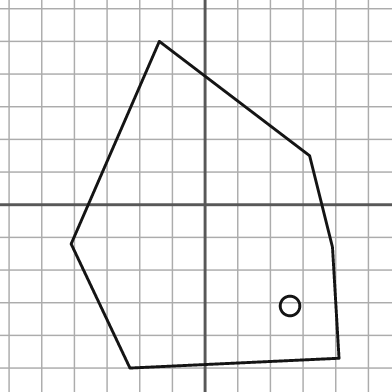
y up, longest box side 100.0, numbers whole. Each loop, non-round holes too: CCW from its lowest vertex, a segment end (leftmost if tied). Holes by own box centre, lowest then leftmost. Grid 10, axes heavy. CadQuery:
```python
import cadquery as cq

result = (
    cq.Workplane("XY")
    .moveTo(-23.0, -50.0)
    .lineTo(41.0, -47.0)
    .lineTo(39.0, -13.0)
    .lineTo(32.0, 15.0)
    .lineTo(-14.0, 50.0)
    .lineTo(-41.0, -12.0)
    .close()
    .moveTo(26.0, -31.0)
    .circle(3.0)
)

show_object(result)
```